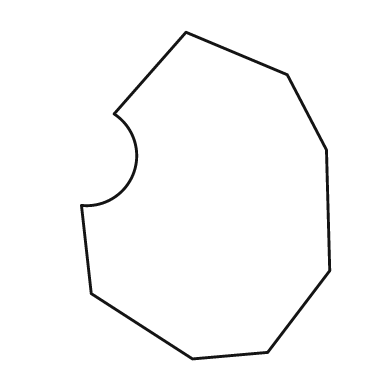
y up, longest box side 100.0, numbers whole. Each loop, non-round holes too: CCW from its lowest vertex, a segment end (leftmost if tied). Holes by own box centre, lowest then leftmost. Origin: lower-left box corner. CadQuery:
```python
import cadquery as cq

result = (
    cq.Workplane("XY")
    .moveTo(34.0, 0.0)
    .lineTo(57.0, 2.0)
    .lineTo(76.0, 27.0)
    .lineTo(75.0, 64.0)
    .lineTo(63.0, 87.0)
    .lineTo(32.0, 100.0)
    .lineTo(10.0, 75.0)
    .threePointArc((16.0, 57.0), (0.0, 47.0))
    .lineTo(3.0, 20.0)
    .close()
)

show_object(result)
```